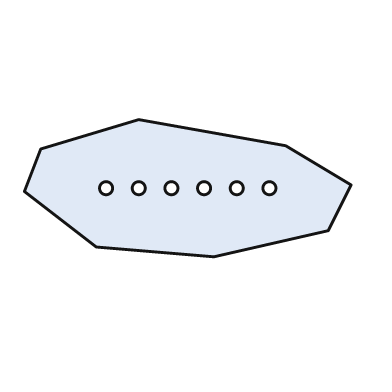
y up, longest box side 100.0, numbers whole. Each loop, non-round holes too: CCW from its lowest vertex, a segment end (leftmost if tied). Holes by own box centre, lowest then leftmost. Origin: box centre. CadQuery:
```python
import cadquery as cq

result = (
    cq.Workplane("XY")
    .moveTo(8.0, -21.0)
    .lineTo(43.0, -13.0)
    .lineTo(50.0, 1.0)
    .lineTo(30.0, 13.0)
    .lineTo(-15.0, 21.0)
    .lineTo(-45.0, 12.0)
    .lineTo(-50.0, -1.0)
    .lineTo(-28.0, -18.0)
    .close()
    .moveTo(-25.0, 0.0)
    .circle(2.0)
    .moveTo(-15.0, 0.0)
    .circle(2.0)
    .moveTo(-5.0, 0.0)
    .circle(2.0)
    .moveTo(5.0, 0.0)
    .circle(2.0)
    .moveTo(15.0, 0.0)
    .circle(2.0)
    .moveTo(25.0, 0.0)
    .circle(2.0)
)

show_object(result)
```